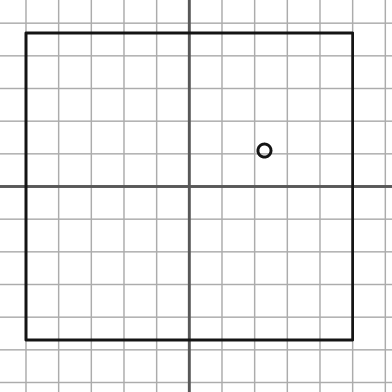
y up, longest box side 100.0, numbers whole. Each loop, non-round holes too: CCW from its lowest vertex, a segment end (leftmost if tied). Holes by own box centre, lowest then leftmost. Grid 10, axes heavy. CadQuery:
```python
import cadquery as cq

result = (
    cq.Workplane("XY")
    .moveTo(-50.0, -47.0)
    .lineTo(50.0, -47.0)
    .lineTo(50.0, 47.0)
    .lineTo(-50.0, 47.0)
    .close()
    .moveTo(23.0, 11.0)
    .circle(2.0)
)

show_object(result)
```